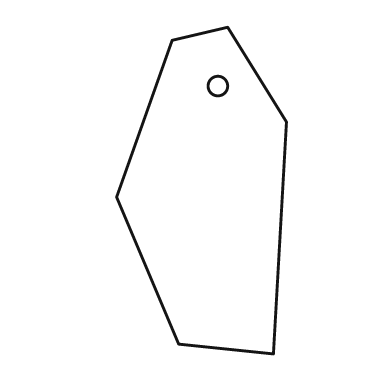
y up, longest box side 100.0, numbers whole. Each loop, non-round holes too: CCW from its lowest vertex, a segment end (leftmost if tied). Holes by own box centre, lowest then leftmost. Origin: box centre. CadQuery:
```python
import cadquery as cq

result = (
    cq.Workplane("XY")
    .moveTo(22.0, -50.0)
    .lineTo(26.0, 21.0)
    .lineTo(8.0, 50.0)
    .lineTo(-9.0, 46.0)
    .lineTo(-26.0, -2.0)
    .lineTo(-7.0, -47.0)
    .close()
    .moveTo(5.0, 32.0)
    .circle(3.0)
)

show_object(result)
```